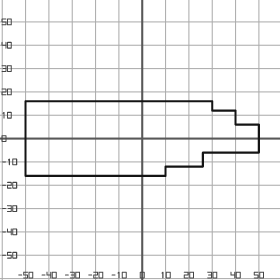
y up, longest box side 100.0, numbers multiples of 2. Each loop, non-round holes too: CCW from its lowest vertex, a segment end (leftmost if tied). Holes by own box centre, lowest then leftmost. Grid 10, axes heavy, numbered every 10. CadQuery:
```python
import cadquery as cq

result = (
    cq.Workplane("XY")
    .moveTo(-50.0, -16.0)
    .lineTo(10.0, -16.0)
    .lineTo(10.0, -12.0)
    .lineTo(26.0, -12.0)
    .lineTo(26.0, -6.0)
    .lineTo(50.0, -6.0)
    .lineTo(50.0, 6.0)
    .lineTo(40.0, 6.0)
    .lineTo(40.0, 12.0)
    .lineTo(30.0, 12.0)
    .lineTo(30.0, 16.0)
    .lineTo(-50.0, 16.0)
    .close()
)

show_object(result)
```